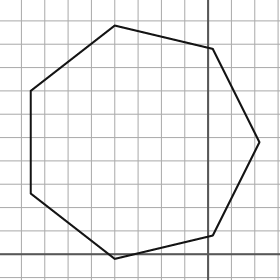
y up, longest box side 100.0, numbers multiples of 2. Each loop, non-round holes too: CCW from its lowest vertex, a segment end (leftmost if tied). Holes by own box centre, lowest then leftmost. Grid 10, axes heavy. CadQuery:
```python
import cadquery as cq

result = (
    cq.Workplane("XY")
    .moveTo(-40.0, -2.0)
    .lineTo(2.0, 8.0)
    .lineTo(22.0, 48.0)
    .lineTo(2.0, 88.0)
    .lineTo(-40.0, 98.0)
    .lineTo(-76.0, 70.0)
    .lineTo(-76.0, 26.0)
    .close()
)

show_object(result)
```